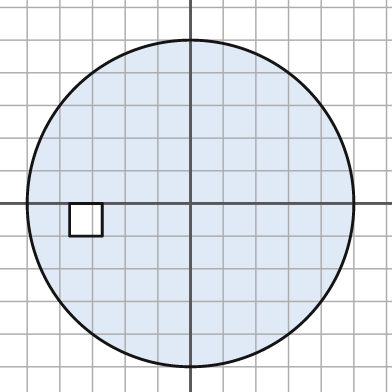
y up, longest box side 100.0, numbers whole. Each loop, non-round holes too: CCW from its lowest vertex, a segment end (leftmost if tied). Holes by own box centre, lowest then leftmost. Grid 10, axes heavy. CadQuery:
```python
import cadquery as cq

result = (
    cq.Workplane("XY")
    .moveTo(0.0, 0.0)
    .circle(50.0)
    .moveTo(-37.0, -10.0)
    .lineTo(-27.0, -10.0)
    .lineTo(-27.0, 0.0)
    .lineTo(-37.0, 0.0)
    .close()
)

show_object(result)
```